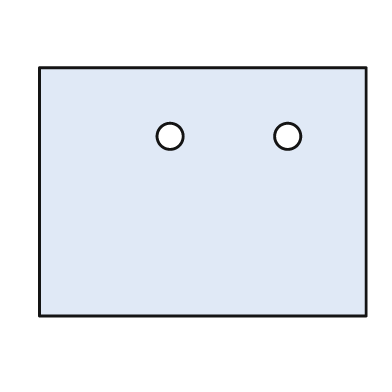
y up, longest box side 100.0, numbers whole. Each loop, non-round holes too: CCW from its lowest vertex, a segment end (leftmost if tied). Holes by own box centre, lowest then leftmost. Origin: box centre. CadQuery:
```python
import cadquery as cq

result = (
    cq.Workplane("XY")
    .moveTo(-50.0, -38.0)
    .lineTo(50.0, -38.0)
    .lineTo(50.0, 38.0)
    .lineTo(-50.0, 38.0)
    .close()
    .moveTo(-10.0, 17.0)
    .circle(4.0)
    .moveTo(26.0, 17.0)
    .circle(4.0)
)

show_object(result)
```